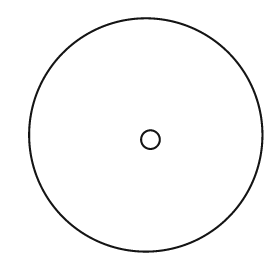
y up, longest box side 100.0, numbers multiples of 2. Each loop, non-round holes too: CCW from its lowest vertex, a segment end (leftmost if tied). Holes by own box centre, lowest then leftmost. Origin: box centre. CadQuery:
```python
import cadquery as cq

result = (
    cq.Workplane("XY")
    .moveTo(0.0, 0.0)
    .circle(50.0)
    .moveTo(2.0, -2.0)
    .circle(4.0)
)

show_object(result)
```